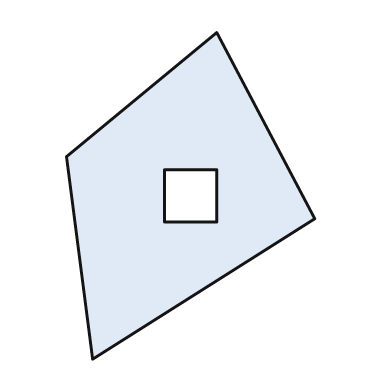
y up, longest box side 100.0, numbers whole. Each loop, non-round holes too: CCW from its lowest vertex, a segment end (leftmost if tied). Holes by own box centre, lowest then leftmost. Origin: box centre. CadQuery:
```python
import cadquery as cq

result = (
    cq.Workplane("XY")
    .moveTo(-30.0, -50.0)
    .lineTo(38.0, -7.0)
    .lineTo(8.0, 50.0)
    .lineTo(-38.0, 12.0)
    .close()
    .moveTo(-8.0, -8.0)
    .lineTo(8.0, -8.0)
    .lineTo(8.0, 8.0)
    .lineTo(-8.0, 8.0)
    .close()
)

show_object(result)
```